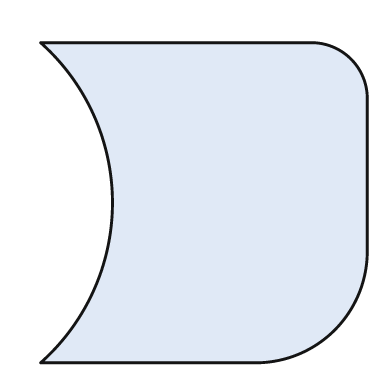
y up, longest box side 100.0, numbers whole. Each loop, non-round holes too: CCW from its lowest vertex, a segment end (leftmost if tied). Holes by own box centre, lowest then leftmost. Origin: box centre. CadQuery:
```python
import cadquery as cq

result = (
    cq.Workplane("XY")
    .moveTo(-50.0, -49.0)
    .lineTo(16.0, -49.0)
    .threePointArc((40.0, -39.0), (50.0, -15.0))
    .lineTo(50.0, 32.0)
    .threePointArc((45.0, 44.0), (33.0, 49.0))
    .lineTo(-50.0, 49.0)
    .threePointArc((-28.0, 0.0), (-50.0, -49.0))
    .close()
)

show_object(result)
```